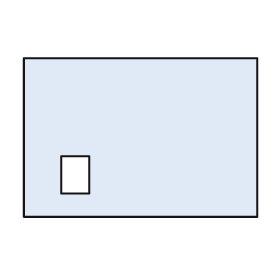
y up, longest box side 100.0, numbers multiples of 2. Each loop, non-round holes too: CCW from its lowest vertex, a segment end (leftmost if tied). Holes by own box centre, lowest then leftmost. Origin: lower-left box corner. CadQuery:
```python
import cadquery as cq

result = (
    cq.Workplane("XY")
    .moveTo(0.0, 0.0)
    .lineTo(100.0, 0.0)
    .lineTo(100.0, 68.0)
    .lineTo(0.0, 68.0)
    .close()
    .moveTo(16.0, 10.0)
    .lineTo(28.0, 10.0)
    .lineTo(28.0, 26.0)
    .lineTo(16.0, 26.0)
    .close()
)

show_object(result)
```